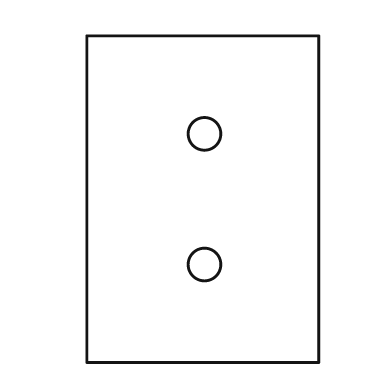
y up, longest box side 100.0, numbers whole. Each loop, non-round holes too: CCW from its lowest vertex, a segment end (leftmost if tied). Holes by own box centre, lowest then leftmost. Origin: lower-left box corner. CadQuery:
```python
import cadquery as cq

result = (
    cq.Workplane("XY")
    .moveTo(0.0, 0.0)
    .lineTo(71.0, 0.0)
    .lineTo(71.0, 100.0)
    .lineTo(0.0, 100.0)
    .close()
    .moveTo(36.0, 30.0)
    .circle(5.0)
    .moveTo(36.0, 70.0)
    .circle(5.0)
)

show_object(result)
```